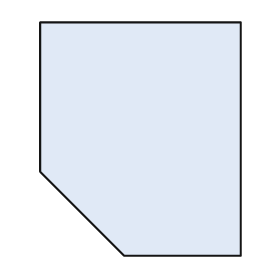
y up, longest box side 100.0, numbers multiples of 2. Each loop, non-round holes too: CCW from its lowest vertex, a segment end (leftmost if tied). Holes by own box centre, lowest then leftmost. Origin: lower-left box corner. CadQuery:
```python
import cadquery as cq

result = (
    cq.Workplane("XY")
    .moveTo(36.0, 0.0)
    .lineTo(86.0, 0.0)
    .lineTo(86.0, 100.0)
    .lineTo(0.0, 100.0)
    .lineTo(0.0, 36.0)
    .close()
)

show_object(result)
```